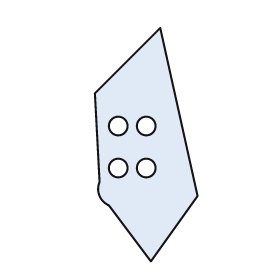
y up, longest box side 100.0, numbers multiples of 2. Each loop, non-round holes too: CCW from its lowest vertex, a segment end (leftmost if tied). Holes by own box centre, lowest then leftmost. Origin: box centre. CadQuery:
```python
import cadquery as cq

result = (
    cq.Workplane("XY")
    .moveTo(2.0, -50.0)
    .lineTo(22.0, -22.0)
    .lineTo(6.0, 50.0)
    .lineTo(-22.0, 22.0)
    .lineTo(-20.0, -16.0)
    .threePointArc((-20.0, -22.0), (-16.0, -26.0))
    .close()
    .moveTo(-12.0, -10.0)
    .circle(4.0)
    .moveTo(0.0, -10.0)
    .circle(4.0)
    .moveTo(-12.0, 8.0)
    .circle(4.0)
    .moveTo(0.0, 8.0)
    .circle(4.0)
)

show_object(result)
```